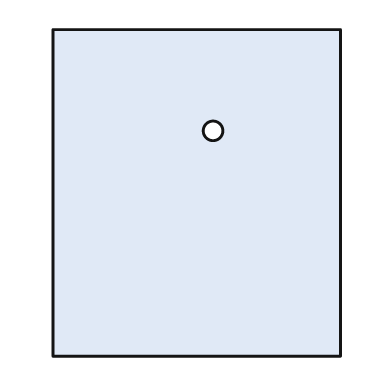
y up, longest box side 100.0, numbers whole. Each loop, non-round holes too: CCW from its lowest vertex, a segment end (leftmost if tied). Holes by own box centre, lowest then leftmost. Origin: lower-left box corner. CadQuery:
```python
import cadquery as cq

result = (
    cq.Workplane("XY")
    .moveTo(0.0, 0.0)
    .lineTo(88.0, 0.0)
    .lineTo(88.0, 100.0)
    .lineTo(0.0, 100.0)
    .close()
    .moveTo(49.0, 69.0)
    .circle(3.0)
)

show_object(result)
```